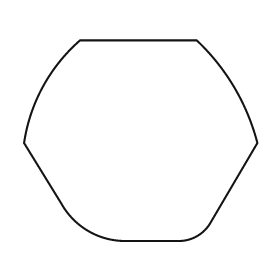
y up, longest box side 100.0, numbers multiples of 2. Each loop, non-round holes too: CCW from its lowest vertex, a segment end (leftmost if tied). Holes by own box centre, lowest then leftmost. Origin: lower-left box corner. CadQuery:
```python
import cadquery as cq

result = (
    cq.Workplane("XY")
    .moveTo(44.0, 0.0)
    .lineTo(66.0, 0.0)
    .threePointArc((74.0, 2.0), (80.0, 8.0))
    .lineTo(100.0, 42.0)
    .threePointArc((90.0, 66.0), (74.0, 86.0))
    .lineTo(24.0, 86.0)
    .threePointArc((8.0, 66.0), (0.0, 42.0))
    .lineTo(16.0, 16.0)
    .threePointArc((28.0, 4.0), (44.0, 0.0))
    .close()
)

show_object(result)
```